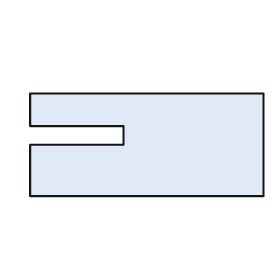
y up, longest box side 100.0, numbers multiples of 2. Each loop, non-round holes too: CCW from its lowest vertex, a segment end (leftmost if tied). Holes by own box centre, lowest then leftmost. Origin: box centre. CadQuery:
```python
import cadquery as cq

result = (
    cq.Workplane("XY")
    .moveTo(-50.0, -22.0)
    .lineTo(50.0, -22.0)
    .lineTo(50.0, 22.0)
    .lineTo(-50.0, 22.0)
    .lineTo(-50.0, 8.0)
    .lineTo(-10.0, 8.0)
    .lineTo(-10.0, 0.0)
    .lineTo(-50.0, 0.0)
    .close()
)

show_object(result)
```